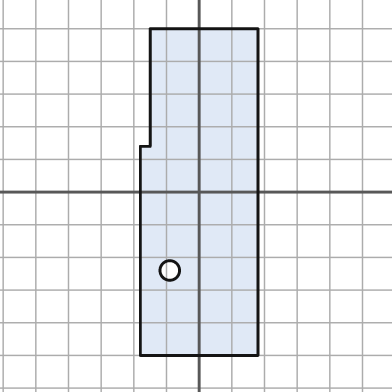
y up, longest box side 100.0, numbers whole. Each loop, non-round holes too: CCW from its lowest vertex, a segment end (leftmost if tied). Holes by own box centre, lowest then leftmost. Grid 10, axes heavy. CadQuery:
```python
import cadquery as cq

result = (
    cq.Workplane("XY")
    .moveTo(-18.0, -50.0)
    .lineTo(18.0, -50.0)
    .lineTo(18.0, 50.0)
    .lineTo(-15.0, 50.0)
    .lineTo(-15.0, 14.0)
    .lineTo(-18.0, 14.0)
    .close()
    .moveTo(-9.0, -24.0)
    .circle(3.0)
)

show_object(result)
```